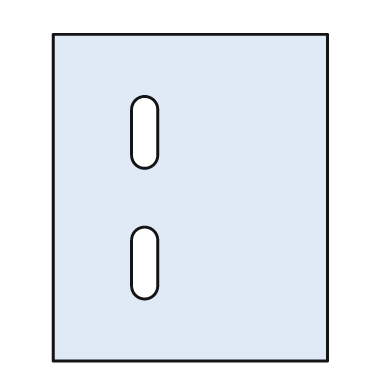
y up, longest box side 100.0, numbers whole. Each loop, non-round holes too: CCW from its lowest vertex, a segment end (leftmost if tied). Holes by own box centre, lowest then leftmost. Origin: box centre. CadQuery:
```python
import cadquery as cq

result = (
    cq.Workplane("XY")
    .moveTo(-42.0, -50.0)
    .lineTo(42.0, -50.0)
    .lineTo(42.0, 50.0)
    .lineTo(-42.0, 50.0)
    .close()
    .moveTo(-18.0, -27.0)
    .threePointArc((-14.0, -31.0), (-10.0, -27.0))
    .lineTo(-10.0, -13.0)
    .threePointArc((-14.0, -9.0), (-18.0, -13.0))
    .close()
    .moveTo(-18.0, 13.0)
    .threePointArc((-14.0, 9.0), (-10.0, 13.0))
    .lineTo(-10.0, 27.0)
    .threePointArc((-14.0, 31.0), (-18.0, 27.0))
    .close()
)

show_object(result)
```